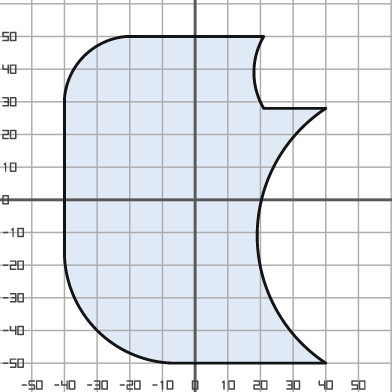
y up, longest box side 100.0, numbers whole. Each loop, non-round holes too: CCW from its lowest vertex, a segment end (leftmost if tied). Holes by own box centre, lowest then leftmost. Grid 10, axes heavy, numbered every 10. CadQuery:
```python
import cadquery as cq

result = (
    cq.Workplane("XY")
    .moveTo(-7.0, -50.0)
    .lineTo(40.0, -50.0)
    .threePointArc((19.0, -11.0), (40.0, 28.0))
    .lineTo(21.0, 28.0)
    .threePointArc((18.0, 39.0), (21.0, 50.0))
    .lineTo(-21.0, 50.0)
    .threePointArc((-34.0, 44.0), (-40.0, 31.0))
    .lineTo(-40.0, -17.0)
    .threePointArc((-30.0, -40.0), (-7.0, -50.0))
    .close()
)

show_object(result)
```